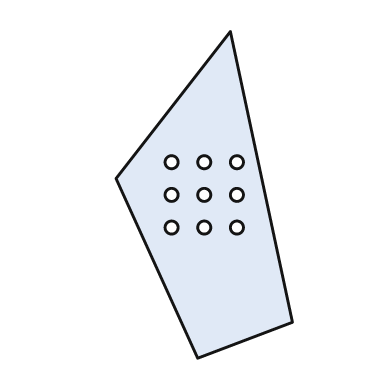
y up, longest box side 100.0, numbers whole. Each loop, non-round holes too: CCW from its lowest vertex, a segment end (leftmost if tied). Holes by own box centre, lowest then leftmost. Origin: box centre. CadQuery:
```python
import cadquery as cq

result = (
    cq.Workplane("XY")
    .moveTo(-2.0, -50.0)
    .lineTo(27.0, -39.0)
    .lineTo(8.0, 50.0)
    .lineTo(-27.0, 5.0)
    .close()
    .moveTo(-10.0, -10.0)
    .circle(2.0)
    .moveTo(0.0, -10.0)
    .circle(2.0)
    .moveTo(10.0, -10.0)
    .circle(2.0)
    .moveTo(-10.0, 0.0)
    .circle(2.0)
    .moveTo(0.0, 0.0)
    .circle(2.0)
    .moveTo(10.0, 0.0)
    .circle(2.0)
    .moveTo(-10.0, 10.0)
    .circle(2.0)
    .moveTo(0.0, 10.0)
    .circle(2.0)
    .moveTo(10.0, 10.0)
    .circle(2.0)
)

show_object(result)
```